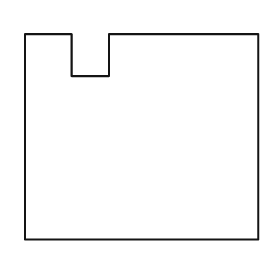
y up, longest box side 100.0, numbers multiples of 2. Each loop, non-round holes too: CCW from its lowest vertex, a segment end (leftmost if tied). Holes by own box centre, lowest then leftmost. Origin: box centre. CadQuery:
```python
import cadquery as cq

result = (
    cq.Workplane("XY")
    .moveTo(-50.0, -44.0)
    .lineTo(50.0, -44.0)
    .lineTo(50.0, 44.0)
    .lineTo(-14.0, 44.0)
    .lineTo(-14.0, 26.0)
    .lineTo(-30.0, 26.0)
    .lineTo(-30.0, 44.0)
    .lineTo(-50.0, 44.0)
    .close()
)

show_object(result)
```